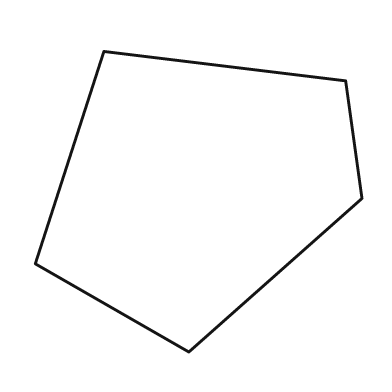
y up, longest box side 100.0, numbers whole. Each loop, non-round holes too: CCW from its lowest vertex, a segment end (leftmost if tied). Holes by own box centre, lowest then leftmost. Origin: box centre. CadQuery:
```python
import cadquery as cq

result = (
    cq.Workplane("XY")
    .moveTo(-3.0, -46.0)
    .lineTo(50.0, 1.0)
    .lineTo(45.0, 37.0)
    .lineTo(-29.0, 46.0)
    .lineTo(-50.0, -19.0)
    .close()
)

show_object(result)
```